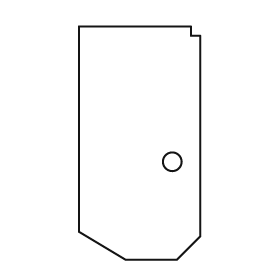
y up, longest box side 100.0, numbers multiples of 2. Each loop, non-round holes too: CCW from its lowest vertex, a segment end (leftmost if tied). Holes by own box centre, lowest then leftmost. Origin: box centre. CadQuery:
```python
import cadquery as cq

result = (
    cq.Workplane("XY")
    .moveTo(-6.0, -50.0)
    .lineTo(16.0, -50.0)
    .lineTo(26.0, -40.0)
    .lineTo(26.0, 46.0)
    .lineTo(22.0, 46.0)
    .lineTo(22.0, 50.0)
    .lineTo(-26.0, 50.0)
    .lineTo(-26.0, -38.0)
    .close()
    .moveTo(14.0, -8.0)
    .circle(4.0)
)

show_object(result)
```